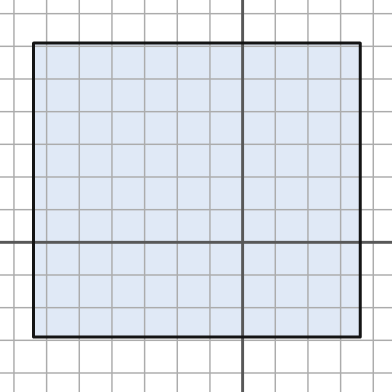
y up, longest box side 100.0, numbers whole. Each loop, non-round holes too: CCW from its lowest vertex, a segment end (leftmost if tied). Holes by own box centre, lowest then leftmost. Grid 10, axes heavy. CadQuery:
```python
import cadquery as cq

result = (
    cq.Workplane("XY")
    .moveTo(-64.0, -29.0)
    .lineTo(36.0, -29.0)
    .lineTo(36.0, 61.0)
    .lineTo(-64.0, 61.0)
    .close()
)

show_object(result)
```